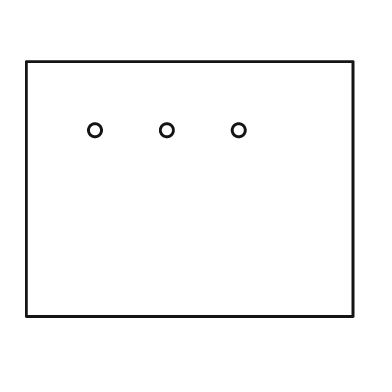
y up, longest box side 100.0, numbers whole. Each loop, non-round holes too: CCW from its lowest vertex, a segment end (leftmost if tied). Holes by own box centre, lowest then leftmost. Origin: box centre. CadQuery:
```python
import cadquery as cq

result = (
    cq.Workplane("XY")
    .moveTo(-50.0, -39.0)
    .lineTo(50.0, -39.0)
    .lineTo(50.0, 39.0)
    .lineTo(-50.0, 39.0)
    .close()
    .moveTo(-29.0, 18.0)
    .circle(2.0)
    .moveTo(-7.0, 18.0)
    .circle(2.0)
    .moveTo(15.0, 18.0)
    .circle(2.0)
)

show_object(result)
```